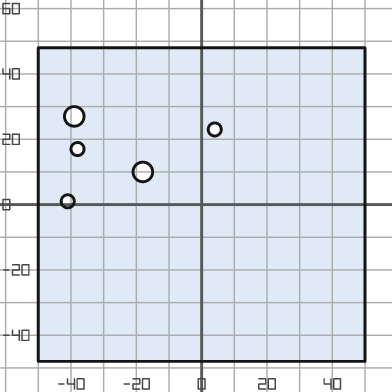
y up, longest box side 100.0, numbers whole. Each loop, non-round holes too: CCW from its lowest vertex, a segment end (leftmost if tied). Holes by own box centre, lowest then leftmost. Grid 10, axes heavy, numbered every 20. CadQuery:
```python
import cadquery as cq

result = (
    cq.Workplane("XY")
    .moveTo(-50.0, -48.0)
    .lineTo(50.0, -48.0)
    .lineTo(50.0, 48.0)
    .lineTo(-50.0, 48.0)
    .close()
    .moveTo(-41.0, 1.0)
    .circle(2.0)
    .moveTo(-18.0, 10.0)
    .circle(3.0)
    .moveTo(-38.0, 17.0)
    .circle(2.0)
    .moveTo(4.0, 23.0)
    .circle(2.0)
    .moveTo(-39.0, 27.0)
    .circle(3.0)
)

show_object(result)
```